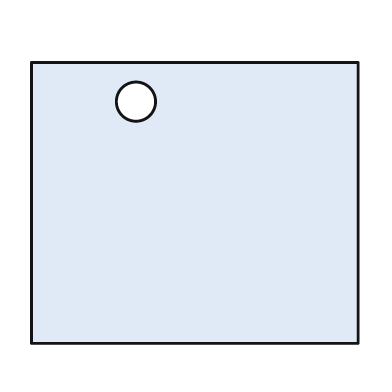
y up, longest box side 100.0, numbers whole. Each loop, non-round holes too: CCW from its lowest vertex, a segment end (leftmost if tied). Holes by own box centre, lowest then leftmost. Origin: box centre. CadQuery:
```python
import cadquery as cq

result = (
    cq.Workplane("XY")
    .moveTo(-50.0, -43.0)
    .lineTo(50.0, -43.0)
    .lineTo(50.0, 43.0)
    .lineTo(-50.0, 43.0)
    .close()
    .moveTo(-18.0, 31.0)
    .circle(6.0)
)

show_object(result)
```